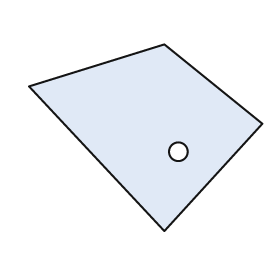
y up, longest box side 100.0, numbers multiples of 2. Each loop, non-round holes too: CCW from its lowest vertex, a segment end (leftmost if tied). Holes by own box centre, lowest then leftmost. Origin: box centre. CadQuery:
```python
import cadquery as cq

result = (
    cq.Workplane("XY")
    .moveTo(8.0, -40.0)
    .lineTo(50.0, 6.0)
    .lineTo(8.0, 40.0)
    .lineTo(-50.0, 22.0)
    .close()
    .moveTo(14.0, -6.0)
    .circle(4.0)
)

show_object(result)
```